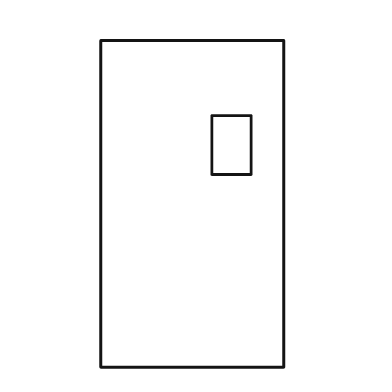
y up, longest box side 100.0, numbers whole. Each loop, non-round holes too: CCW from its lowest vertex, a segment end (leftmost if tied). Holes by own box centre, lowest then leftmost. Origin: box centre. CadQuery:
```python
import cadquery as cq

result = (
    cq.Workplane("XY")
    .moveTo(-28.0, -50.0)
    .lineTo(28.0, -50.0)
    .lineTo(28.0, 50.0)
    .lineTo(-28.0, 50.0)
    .close()
    .moveTo(6.0, 9.0)
    .lineTo(18.0, 9.0)
    .lineTo(18.0, 27.0)
    .lineTo(6.0, 27.0)
    .close()
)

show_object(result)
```